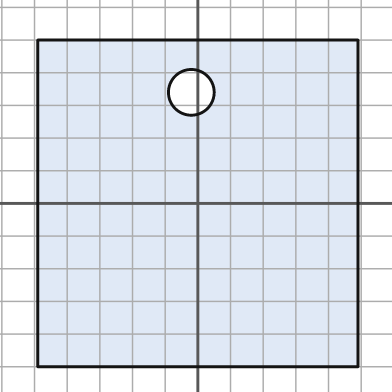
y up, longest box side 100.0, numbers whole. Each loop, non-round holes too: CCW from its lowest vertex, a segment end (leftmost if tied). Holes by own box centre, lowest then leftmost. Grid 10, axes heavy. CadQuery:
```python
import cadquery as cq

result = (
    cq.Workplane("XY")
    .moveTo(-49.0, -50.0)
    .lineTo(49.0, -50.0)
    .lineTo(49.0, 50.0)
    .lineTo(-49.0, 50.0)
    .close()
    .moveTo(-2.0, 34.0)
    .circle(7.0)
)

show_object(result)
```